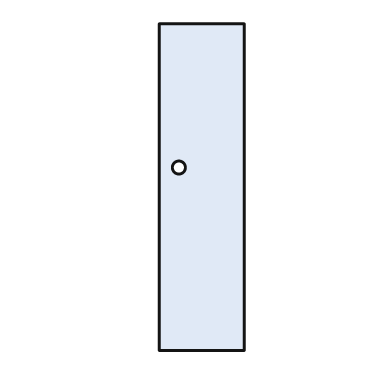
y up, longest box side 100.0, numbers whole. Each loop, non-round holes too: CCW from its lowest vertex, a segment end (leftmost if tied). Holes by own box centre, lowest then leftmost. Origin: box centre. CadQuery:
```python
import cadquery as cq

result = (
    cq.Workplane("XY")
    .moveTo(-13.0, -50.0)
    .lineTo(13.0, -50.0)
    .lineTo(13.0, 50.0)
    .lineTo(-13.0, 50.0)
    .close()
    .moveTo(-7.0, 6.0)
    .circle(2.0)
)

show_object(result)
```